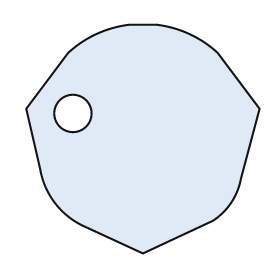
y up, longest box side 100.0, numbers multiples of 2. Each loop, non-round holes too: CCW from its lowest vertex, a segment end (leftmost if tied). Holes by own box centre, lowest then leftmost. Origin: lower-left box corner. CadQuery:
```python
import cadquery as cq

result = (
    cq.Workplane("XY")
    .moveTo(50.0, 0.0)
    .lineTo(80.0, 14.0)
    .threePointArc((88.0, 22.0), (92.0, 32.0))
    .lineTo(100.0, 62.0)
    .lineTo(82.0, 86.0)
    .threePointArc((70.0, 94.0), (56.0, 98.0))
    .lineTo(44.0, 98.0)
    .threePointArc((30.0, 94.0), (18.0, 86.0))
    .lineTo(0.0, 62.0)
    .lineTo(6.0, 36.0)
    .threePointArc((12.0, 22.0), (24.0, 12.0))
    .close()
    .moveTo(20.0, 60.0)
    .circle(8.0)
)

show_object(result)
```